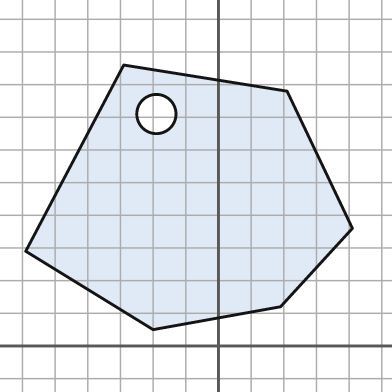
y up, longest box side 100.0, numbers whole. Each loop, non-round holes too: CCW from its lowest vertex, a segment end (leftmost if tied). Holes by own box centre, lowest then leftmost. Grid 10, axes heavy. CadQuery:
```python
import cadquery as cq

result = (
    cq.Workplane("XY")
    .moveTo(-20.0, 5.0)
    .lineTo(19.0, 12.0)
    .lineTo(41.0, 36.0)
    .lineTo(21.0, 78.0)
    .lineTo(-29.0, 86.0)
    .lineTo(-59.0, 29.0)
    .close()
    .moveTo(-19.0, 71.0)
    .circle(6.0)
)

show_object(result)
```